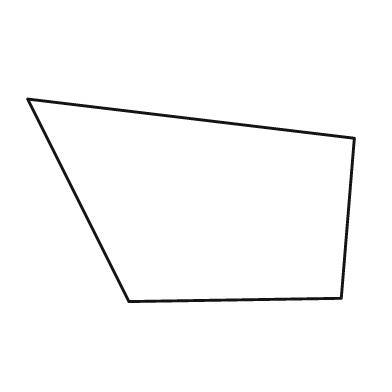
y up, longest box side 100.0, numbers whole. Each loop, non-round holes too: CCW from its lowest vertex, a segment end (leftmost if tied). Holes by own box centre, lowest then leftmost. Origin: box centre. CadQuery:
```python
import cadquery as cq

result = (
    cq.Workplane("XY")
    .moveTo(-19.0, -31.0)
    .lineTo(46.0, -30.0)
    .lineTo(50.0, 19.0)
    .lineTo(-50.0, 31.0)
    .close()
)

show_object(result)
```